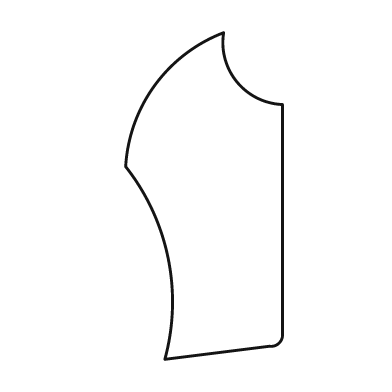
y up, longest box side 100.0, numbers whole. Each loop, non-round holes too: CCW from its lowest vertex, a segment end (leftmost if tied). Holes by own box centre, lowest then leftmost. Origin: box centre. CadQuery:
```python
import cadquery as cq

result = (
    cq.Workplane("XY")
    .moveTo(-12.0, -50.0)
    .lineTo(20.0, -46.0)
    .threePointArc((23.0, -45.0), (24.0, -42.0))
    .lineTo(24.0, 28.0)
    .threePointArc((10.0, 35.0), (6.0, 50.0))
    .threePointArc((-15.0, 34.0), (-24.0, 9.0))
    .threePointArc((-11.0, -19.0), (-12.0, -50.0))
    .close()
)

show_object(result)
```